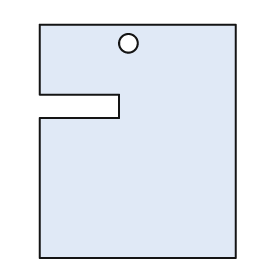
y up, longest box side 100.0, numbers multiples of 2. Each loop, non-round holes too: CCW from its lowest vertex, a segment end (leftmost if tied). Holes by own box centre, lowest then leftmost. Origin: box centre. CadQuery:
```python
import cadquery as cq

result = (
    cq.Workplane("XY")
    .moveTo(-42.0, -50.0)
    .lineTo(42.0, -50.0)
    .lineTo(42.0, 50.0)
    .lineTo(-42.0, 50.0)
    .lineTo(-42.0, 20.0)
    .lineTo(-8.0, 20.0)
    .lineTo(-8.0, 10.0)
    .lineTo(-42.0, 10.0)
    .close()
    .moveTo(-4.0, 42.0)
    .circle(4.0)
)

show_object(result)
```